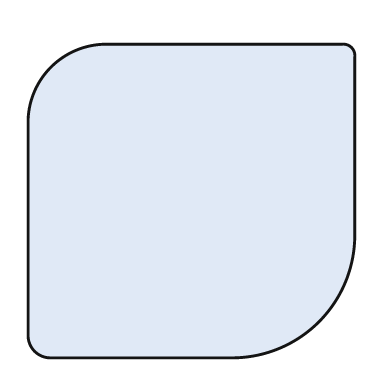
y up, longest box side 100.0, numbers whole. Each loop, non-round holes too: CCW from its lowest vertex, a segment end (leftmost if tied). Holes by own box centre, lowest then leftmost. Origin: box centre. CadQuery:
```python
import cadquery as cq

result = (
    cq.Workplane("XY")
    .moveTo(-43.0, -48.0)
    .lineTo(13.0, -48.0)
    .threePointArc((39.0, -37.0), (50.0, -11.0))
    .lineTo(50.0, 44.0)
    .threePointArc((49.0, 47.0), (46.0, 48.0))
    .lineTo(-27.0, 48.0)
    .threePointArc((-43.0, 41.0), (-50.0, 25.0))
    .lineTo(-50.0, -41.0)
    .threePointArc((-48.0, -46.0), (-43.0, -48.0))
    .close()
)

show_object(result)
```